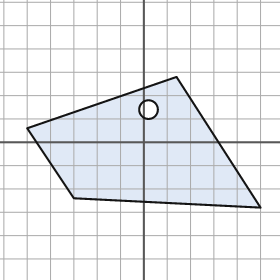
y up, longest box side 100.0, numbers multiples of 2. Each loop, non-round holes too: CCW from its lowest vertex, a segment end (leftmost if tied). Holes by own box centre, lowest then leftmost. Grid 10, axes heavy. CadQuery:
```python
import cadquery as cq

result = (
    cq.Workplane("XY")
    .moveTo(50.0, -28.0)
    .lineTo(14.0, 28.0)
    .lineTo(-50.0, 6.0)
    .lineTo(-30.0, -24.0)
    .close()
    .moveTo(2.0, 14.0)
    .circle(4.0)
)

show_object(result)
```